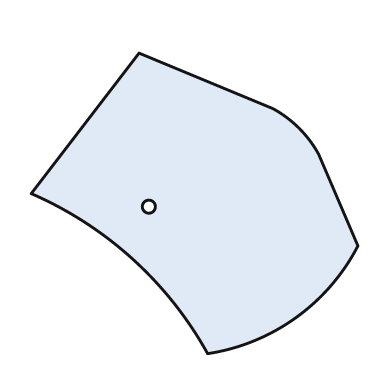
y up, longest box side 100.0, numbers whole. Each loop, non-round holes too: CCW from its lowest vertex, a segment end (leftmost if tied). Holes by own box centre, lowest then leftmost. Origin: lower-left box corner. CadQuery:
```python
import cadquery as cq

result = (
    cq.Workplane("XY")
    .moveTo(54.0, 0.0)
    .threePointArc((81.0, 11.0), (100.0, 33.0))
    .lineTo(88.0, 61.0)
    .threePointArc((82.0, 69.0), (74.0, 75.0))
    .lineTo(33.0, 92.0)
    .lineTo(0.0, 49.0)
    .threePointArc((31.0, 29.0), (54.0, 0.0))
    .close()
    .moveTo(36.0, 45.0)
    .circle(2.0)
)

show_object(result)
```